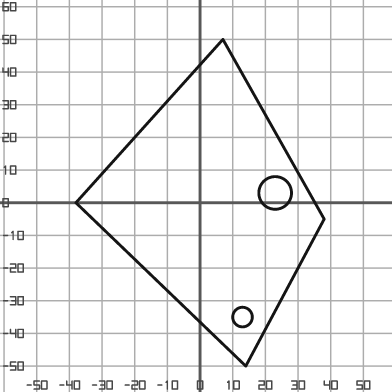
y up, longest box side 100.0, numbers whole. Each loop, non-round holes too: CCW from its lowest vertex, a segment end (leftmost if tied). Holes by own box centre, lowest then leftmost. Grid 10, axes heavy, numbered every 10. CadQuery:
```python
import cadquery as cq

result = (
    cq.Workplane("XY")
    .moveTo(14.0, -50.0)
    .lineTo(38.0, -5.0)
    .lineTo(7.0, 50.0)
    .lineTo(-38.0, 0.0)
    .close()
    .moveTo(13.0, -35.0)
    .circle(3.0)
    .moveTo(23.0, 3.0)
    .circle(5.0)
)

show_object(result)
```